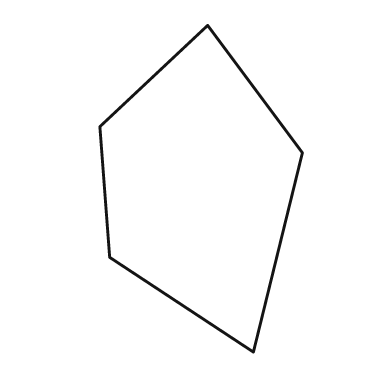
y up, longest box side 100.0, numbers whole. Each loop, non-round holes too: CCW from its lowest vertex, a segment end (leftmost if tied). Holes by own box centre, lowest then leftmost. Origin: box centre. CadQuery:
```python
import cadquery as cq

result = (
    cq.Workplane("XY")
    .moveTo(16.0, -50.0)
    .lineTo(31.0, 11.0)
    .lineTo(2.0, 50.0)
    .lineTo(-31.0, 19.0)
    .lineTo(-28.0, -21.0)
    .close()
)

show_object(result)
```